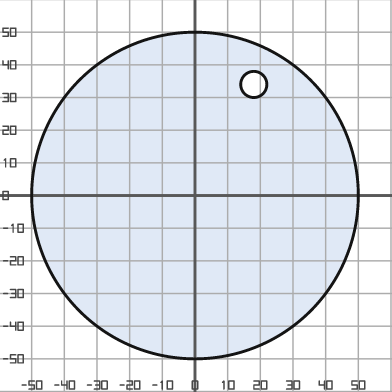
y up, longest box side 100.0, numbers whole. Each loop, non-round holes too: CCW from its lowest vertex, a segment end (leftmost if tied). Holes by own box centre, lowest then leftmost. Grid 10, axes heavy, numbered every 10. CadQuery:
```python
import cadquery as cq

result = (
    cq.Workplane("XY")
    .moveTo(0.0, 0.0)
    .circle(50.0)
    .moveTo(18.0, 34.0)
    .circle(4.0)
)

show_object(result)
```